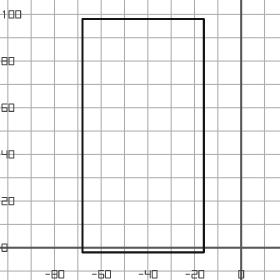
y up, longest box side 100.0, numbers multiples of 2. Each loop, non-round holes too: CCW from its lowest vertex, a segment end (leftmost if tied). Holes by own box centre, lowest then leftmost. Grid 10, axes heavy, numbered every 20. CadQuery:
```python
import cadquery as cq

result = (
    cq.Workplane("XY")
    .moveTo(-68.0, -2.0)
    .lineTo(-16.0, -2.0)
    .lineTo(-16.0, 98.0)
    .lineTo(-68.0, 98.0)
    .close()
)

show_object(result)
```